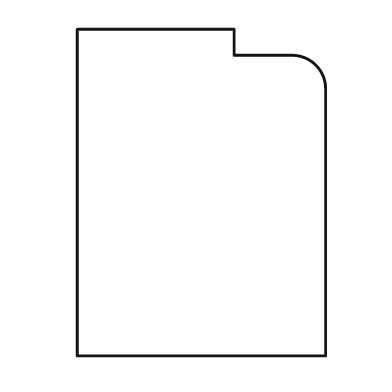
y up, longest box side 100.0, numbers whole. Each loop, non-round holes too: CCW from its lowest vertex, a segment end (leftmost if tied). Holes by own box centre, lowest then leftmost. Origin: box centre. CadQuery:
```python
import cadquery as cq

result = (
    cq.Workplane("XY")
    .moveTo(-38.0, -50.0)
    .lineTo(38.0, -50.0)
    .lineTo(38.0, 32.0)
    .threePointArc((35.0, 39.0), (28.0, 42.0))
    .lineTo(10.0, 42.0)
    .lineTo(10.0, 50.0)
    .lineTo(-38.0, 50.0)
    .close()
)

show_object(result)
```